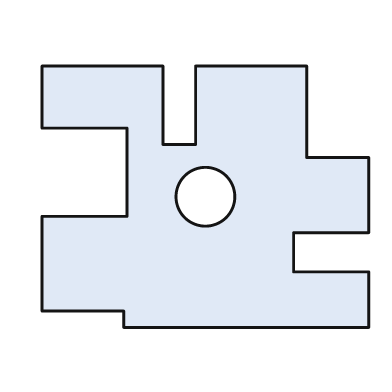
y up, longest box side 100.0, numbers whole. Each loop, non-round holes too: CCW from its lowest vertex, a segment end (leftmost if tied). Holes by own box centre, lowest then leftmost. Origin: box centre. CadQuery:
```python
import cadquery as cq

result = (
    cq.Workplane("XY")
    .moveTo(-25.0, -40.0)
    .lineTo(50.0, -40.0)
    .lineTo(50.0, -23.0)
    .lineTo(27.0, -23.0)
    .lineTo(27.0, -11.0)
    .lineTo(50.0, -11.0)
    .lineTo(50.0, 12.0)
    .lineTo(31.0, 12.0)
    .lineTo(31.0, 40.0)
    .lineTo(-3.0, 40.0)
    .lineTo(-3.0, 16.0)
    .lineTo(-13.0, 16.0)
    .lineTo(-13.0, 40.0)
    .lineTo(-50.0, 40.0)
    .lineTo(-50.0, 21.0)
    .lineTo(-24.0, 21.0)
    .lineTo(-24.0, -6.0)
    .lineTo(-50.0, -6.0)
    .lineTo(-50.0, -35.0)
    .lineTo(-25.0, -35.0)
    .close()
    .moveTo(0.0, 0.0)
    .circle(9.0)
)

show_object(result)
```